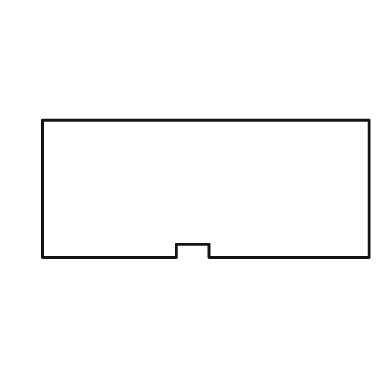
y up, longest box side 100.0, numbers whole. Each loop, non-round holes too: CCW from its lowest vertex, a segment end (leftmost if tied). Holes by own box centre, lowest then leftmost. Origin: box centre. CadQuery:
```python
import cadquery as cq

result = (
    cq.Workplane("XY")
    .moveTo(-50.0, -21.0)
    .lineTo(-9.0, -21.0)
    .lineTo(-9.0, -17.0)
    .lineTo(1.0, -17.0)
    .lineTo(1.0, -21.0)
    .lineTo(50.0, -21.0)
    .lineTo(50.0, 21.0)
    .lineTo(-50.0, 21.0)
    .close()
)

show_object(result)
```